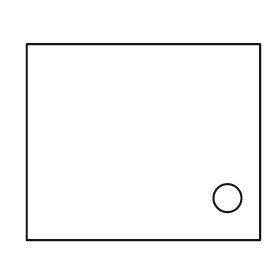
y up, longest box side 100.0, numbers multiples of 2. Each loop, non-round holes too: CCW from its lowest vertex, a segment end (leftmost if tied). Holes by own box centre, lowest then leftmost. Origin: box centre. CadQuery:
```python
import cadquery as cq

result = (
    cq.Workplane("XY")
    .moveTo(-50.0, -42.0)
    .lineTo(50.0, -42.0)
    .lineTo(50.0, 42.0)
    .lineTo(-50.0, 42.0)
    .close()
    .moveTo(36.0, -24.0)
    .circle(6.0)
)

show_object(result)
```